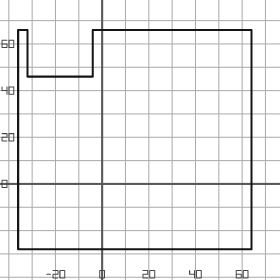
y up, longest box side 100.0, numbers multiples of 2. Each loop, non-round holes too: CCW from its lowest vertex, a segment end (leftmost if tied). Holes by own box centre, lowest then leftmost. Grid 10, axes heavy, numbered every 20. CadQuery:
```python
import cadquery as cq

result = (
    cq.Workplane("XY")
    .moveTo(-36.0, -28.0)
    .lineTo(64.0, -28.0)
    .lineTo(64.0, 66.0)
    .lineTo(-4.0, 66.0)
    .lineTo(-4.0, 46.0)
    .lineTo(-32.0, 46.0)
    .lineTo(-32.0, 66.0)
    .lineTo(-36.0, 66.0)
    .close()
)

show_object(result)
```